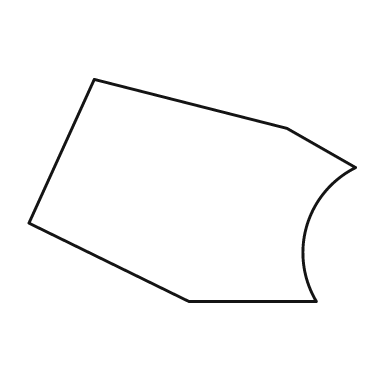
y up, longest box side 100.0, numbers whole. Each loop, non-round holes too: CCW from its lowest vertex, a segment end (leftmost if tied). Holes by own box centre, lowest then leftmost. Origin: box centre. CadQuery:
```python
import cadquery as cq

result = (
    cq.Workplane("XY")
    .moveTo(-1.0, -34.0)
    .lineTo(38.0, -34.0)
    .threePointArc((35.0, -11.0), (50.0, 7.0))
    .lineTo(29.0, 19.0)
    .lineTo(-30.0, 34.0)
    .lineTo(-50.0, -10.0)
    .close()
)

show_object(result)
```